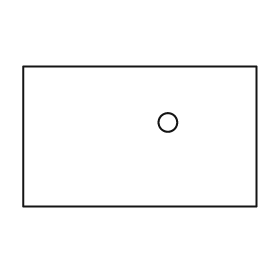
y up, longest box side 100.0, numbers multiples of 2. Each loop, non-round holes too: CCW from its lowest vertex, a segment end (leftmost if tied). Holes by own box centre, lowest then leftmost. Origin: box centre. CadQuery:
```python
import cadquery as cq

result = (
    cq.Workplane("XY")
    .moveTo(-50.0, -30.0)
    .lineTo(50.0, -30.0)
    .lineTo(50.0, 30.0)
    .lineTo(-50.0, 30.0)
    .close()
    .moveTo(12.0, 6.0)
    .circle(4.0)
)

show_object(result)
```